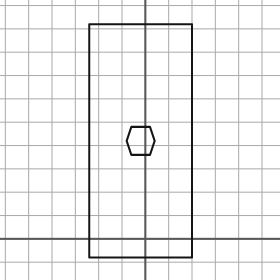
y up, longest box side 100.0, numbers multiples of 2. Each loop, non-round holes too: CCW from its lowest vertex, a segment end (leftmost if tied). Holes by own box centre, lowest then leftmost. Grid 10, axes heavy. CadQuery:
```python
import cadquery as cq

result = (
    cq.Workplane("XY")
    .moveTo(-24.0, -8.0)
    .lineTo(20.0, -8.0)
    .lineTo(20.0, 92.0)
    .lineTo(-24.0, 92.0)
    .close()
    .moveTo(-6.0, 36.0)
    .lineTo(2.0, 36.0)
    .lineTo(4.0, 42.0)
    .lineTo(2.0, 48.0)
    .lineTo(-6.0, 48.0)
    .lineTo(-8.0, 42.0)
    .close()
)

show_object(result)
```